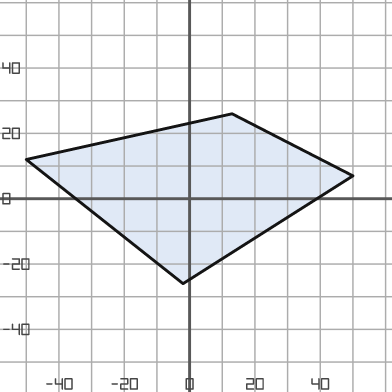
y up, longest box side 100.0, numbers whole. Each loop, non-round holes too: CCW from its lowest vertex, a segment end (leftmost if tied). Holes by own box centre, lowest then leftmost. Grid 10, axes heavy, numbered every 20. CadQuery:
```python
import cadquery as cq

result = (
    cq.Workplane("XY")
    .moveTo(-2.0, -26.0)
    .lineTo(50.0, 7.0)
    .lineTo(13.0, 26.0)
    .lineTo(-50.0, 12.0)
    .close()
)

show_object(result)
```